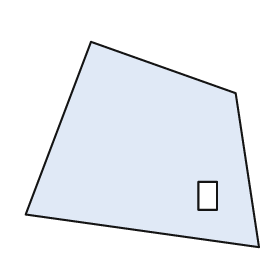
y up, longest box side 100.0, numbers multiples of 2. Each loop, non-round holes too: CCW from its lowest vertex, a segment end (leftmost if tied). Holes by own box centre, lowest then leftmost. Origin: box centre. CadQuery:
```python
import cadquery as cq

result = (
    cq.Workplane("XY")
    .moveTo(50.0, -44.0)
    .lineTo(40.0, 22.0)
    .lineTo(-22.0, 44.0)
    .lineTo(-50.0, -30.0)
    .close()
    .moveTo(24.0, -28.0)
    .lineTo(32.0, -28.0)
    .lineTo(32.0, -16.0)
    .lineTo(24.0, -16.0)
    .close()
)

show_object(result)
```